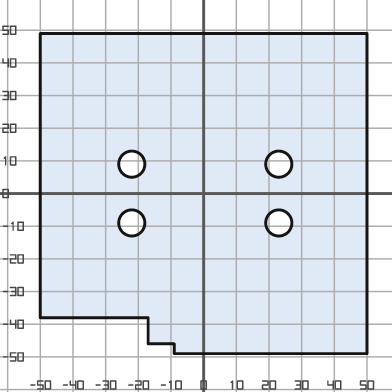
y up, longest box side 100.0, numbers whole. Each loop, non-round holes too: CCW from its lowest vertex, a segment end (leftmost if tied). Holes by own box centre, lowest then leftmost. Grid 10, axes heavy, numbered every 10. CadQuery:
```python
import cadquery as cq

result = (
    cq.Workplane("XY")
    .moveTo(-9.0, -49.0)
    .lineTo(50.0, -49.0)
    .lineTo(50.0, 49.0)
    .lineTo(-50.0, 49.0)
    .lineTo(-50.0, -38.0)
    .lineTo(-17.0, -38.0)
    .lineTo(-17.0, -46.0)
    .lineTo(-9.0, -46.0)
    .close()
    .moveTo(-22.0, -9.0)
    .circle(4.0)
    .moveTo(23.0, -9.0)
    .circle(4.0)
    .moveTo(-22.0, 9.0)
    .circle(4.0)
    .moveTo(23.0, 9.0)
    .circle(4.0)
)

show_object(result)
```